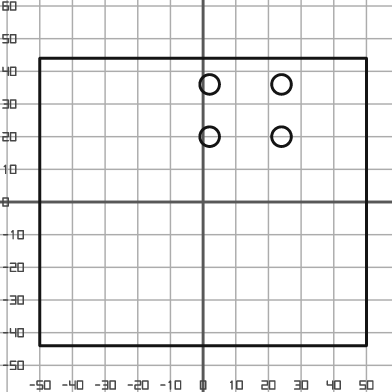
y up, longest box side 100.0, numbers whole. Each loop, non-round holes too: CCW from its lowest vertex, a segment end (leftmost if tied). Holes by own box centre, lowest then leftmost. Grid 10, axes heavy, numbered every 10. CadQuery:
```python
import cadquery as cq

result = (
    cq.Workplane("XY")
    .moveTo(-50.0, -44.0)
    .lineTo(50.0, -44.0)
    .lineTo(50.0, 44.0)
    .lineTo(-50.0, 44.0)
    .close()
    .moveTo(2.0, 20.0)
    .circle(3.0)
    .moveTo(24.0, 20.0)
    .circle(3.0)
    .moveTo(2.0, 36.0)
    .circle(3.0)
    .moveTo(24.0, 36.0)
    .circle(3.0)
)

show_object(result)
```